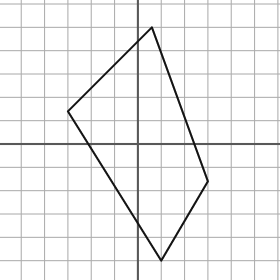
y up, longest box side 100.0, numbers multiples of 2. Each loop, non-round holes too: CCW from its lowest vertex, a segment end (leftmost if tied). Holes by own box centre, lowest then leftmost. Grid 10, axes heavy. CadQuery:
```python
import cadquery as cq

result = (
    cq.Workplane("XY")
    .moveTo(10.0, -50.0)
    .lineTo(30.0, -16.0)
    .lineTo(6.0, 50.0)
    .lineTo(-30.0, 14.0)
    .close()
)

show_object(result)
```